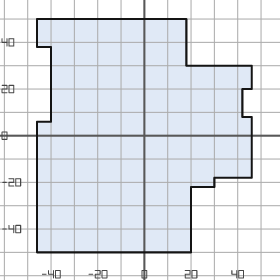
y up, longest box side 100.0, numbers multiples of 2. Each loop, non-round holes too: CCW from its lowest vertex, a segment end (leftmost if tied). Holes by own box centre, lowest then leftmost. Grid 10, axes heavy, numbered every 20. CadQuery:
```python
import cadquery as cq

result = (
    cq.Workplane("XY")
    .moveTo(-46.0, -50.0)
    .lineTo(20.0, -50.0)
    .lineTo(20.0, -22.0)
    .lineTo(30.0, -22.0)
    .lineTo(30.0, -18.0)
    .lineTo(46.0, -18.0)
    .lineTo(46.0, 8.0)
    .lineTo(42.0, 8.0)
    .lineTo(42.0, 20.0)
    .lineTo(46.0, 20.0)
    .lineTo(46.0, 30.0)
    .lineTo(18.0, 30.0)
    .lineTo(18.0, 50.0)
    .lineTo(-46.0, 50.0)
    .lineTo(-46.0, 38.0)
    .lineTo(-40.0, 38.0)
    .lineTo(-40.0, 6.0)
    .lineTo(-46.0, 6.0)
    .close()
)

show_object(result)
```